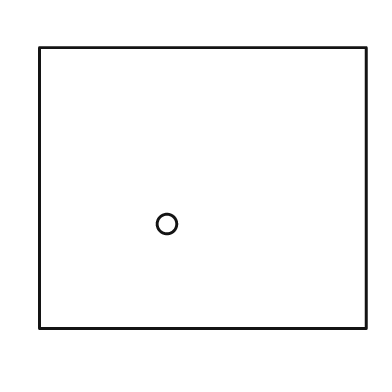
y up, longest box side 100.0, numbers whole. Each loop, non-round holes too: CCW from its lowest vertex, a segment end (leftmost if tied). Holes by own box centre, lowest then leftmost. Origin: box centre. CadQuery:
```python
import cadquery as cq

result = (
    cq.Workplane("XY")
    .moveTo(-50.0, -43.0)
    .lineTo(50.0, -43.0)
    .lineTo(50.0, 43.0)
    .lineTo(-50.0, 43.0)
    .close()
    .moveTo(-11.0, -11.0)
    .circle(3.0)
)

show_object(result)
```